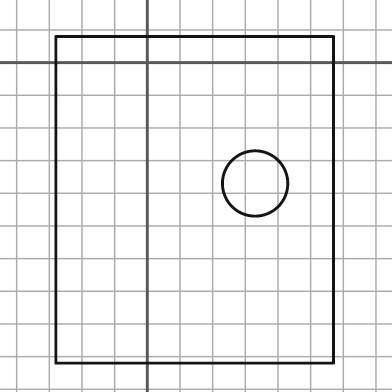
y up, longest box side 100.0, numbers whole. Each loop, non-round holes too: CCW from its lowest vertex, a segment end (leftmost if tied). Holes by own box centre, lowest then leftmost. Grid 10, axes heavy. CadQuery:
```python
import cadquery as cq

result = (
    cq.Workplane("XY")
    .moveTo(-28.0, -92.0)
    .lineTo(57.0, -92.0)
    .lineTo(57.0, 8.0)
    .lineTo(-28.0, 8.0)
    .close()
    .moveTo(33.0, -37.0)
    .circle(10.0)
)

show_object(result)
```